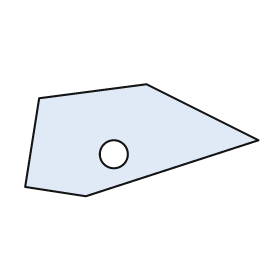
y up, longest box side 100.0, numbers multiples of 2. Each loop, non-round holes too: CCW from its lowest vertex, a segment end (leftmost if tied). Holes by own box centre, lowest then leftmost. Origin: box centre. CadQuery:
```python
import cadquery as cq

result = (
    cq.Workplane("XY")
    .moveTo(-24.0, -24.0)
    .lineTo(50.0, 0.0)
    .lineTo(2.0, 24.0)
    .lineTo(-44.0, 18.0)
    .lineTo(-50.0, -20.0)
    .close()
    .moveTo(-12.0, -6.0)
    .circle(6.0)
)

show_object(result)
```